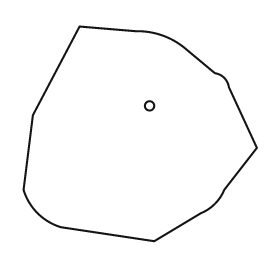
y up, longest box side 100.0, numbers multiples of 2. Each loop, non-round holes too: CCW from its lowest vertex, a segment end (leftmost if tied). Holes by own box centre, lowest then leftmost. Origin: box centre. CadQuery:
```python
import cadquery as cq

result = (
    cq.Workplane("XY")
    .moveTo(6.0, -46.0)
    .lineTo(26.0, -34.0)
    .threePointArc((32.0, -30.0), (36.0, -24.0))
    .lineTo(50.0, -6.0)
    .lineTo(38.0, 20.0)
    .threePointArc((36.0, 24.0), (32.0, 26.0))
    .lineTo(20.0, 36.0)
    .threePointArc((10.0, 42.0), (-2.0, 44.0))
    .lineTo(-26.0, 46.0)
    .lineTo(-46.0, 8.0)
    .lineTo(-50.0, -24.0)
    .threePointArc((-44.0, -34.0), (-34.0, -40.0))
    .close()
    .moveTo(4.0, 12.0)
    .circle(2.0)
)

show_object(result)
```